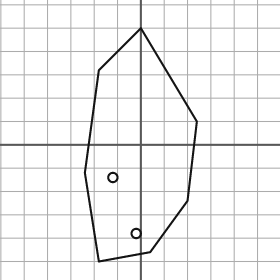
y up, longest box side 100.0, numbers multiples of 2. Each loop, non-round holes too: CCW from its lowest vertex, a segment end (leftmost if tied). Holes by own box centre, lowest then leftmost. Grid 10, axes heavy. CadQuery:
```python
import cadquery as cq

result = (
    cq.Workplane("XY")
    .moveTo(-18.0, -50.0)
    .lineTo(4.0, -46.0)
    .lineTo(20.0, -24.0)
    .lineTo(24.0, 10.0)
    .lineTo(0.0, 50.0)
    .lineTo(-18.0, 32.0)
    .lineTo(-24.0, -12.0)
    .close()
    .moveTo(-2.0, -38.0)
    .circle(2.0)
    .moveTo(-12.0, -14.0)
    .circle(2.0)
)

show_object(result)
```